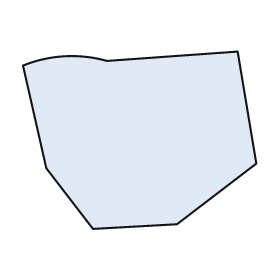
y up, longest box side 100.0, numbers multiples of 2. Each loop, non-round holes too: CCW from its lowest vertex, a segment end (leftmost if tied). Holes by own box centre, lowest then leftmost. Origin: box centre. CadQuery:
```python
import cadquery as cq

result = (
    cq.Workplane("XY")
    .moveTo(-20.0, -38.0)
    .lineTo(16.0, -36.0)
    .lineTo(50.0, -10.0)
    .lineTo(42.0, 38.0)
    .lineTo(-14.0, 34.0)
    .threePointArc((-32.0, 36.0), (-50.0, 32.0))
    .lineTo(-40.0, -12.0)
    .close()
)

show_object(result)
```